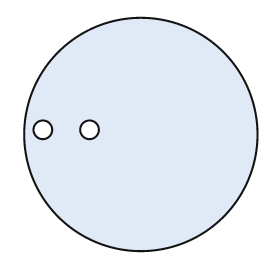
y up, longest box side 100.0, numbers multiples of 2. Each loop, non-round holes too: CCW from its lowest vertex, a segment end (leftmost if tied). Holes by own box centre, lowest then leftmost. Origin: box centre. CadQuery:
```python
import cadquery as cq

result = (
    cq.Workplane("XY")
    .moveTo(0.0, 0.0)
    .circle(50.0)
    .moveTo(-42.0, 2.0)
    .circle(4.0)
    .moveTo(-22.0, 2.0)
    .circle(4.0)
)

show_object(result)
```